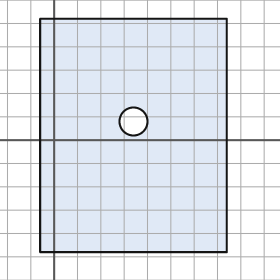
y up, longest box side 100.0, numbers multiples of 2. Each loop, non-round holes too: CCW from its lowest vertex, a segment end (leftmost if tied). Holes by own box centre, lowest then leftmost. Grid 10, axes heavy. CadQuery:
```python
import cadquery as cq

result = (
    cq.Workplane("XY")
    .moveTo(-6.0, -48.0)
    .lineTo(74.0, -48.0)
    .lineTo(74.0, 52.0)
    .lineTo(-6.0, 52.0)
    .close()
    .moveTo(34.0, 8.0)
    .circle(6.0)
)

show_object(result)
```